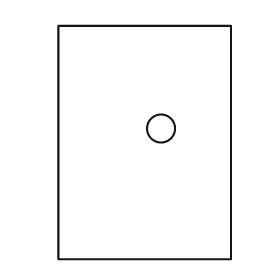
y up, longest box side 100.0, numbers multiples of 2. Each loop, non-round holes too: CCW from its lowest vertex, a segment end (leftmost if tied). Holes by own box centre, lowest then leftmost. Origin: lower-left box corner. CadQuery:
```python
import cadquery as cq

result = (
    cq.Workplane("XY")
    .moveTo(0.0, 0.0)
    .lineTo(74.0, 0.0)
    .lineTo(74.0, 100.0)
    .lineTo(0.0, 100.0)
    .close()
    .moveTo(44.0, 56.0)
    .circle(6.0)
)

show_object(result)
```